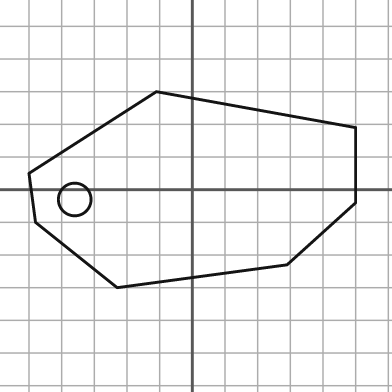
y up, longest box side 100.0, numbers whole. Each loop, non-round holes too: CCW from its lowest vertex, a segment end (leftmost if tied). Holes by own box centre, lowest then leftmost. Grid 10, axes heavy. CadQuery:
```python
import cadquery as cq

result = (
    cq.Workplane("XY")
    .moveTo(-23.0, -30.0)
    .lineTo(29.0, -23.0)
    .lineTo(50.0, -4.0)
    .lineTo(50.0, 19.0)
    .lineTo(-11.0, 30.0)
    .lineTo(-50.0, 5.0)
    .lineTo(-48.0, -10.0)
    .close()
    .moveTo(-36.0, -3.0)
    .circle(5.0)
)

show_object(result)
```